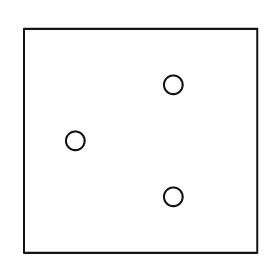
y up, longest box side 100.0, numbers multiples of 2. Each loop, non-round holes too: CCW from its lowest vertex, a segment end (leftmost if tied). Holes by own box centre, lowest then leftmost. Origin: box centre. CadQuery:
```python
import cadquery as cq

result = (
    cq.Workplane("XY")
    .moveTo(-50.0, -48.0)
    .lineTo(50.0, -48.0)
    .lineTo(50.0, 48.0)
    .lineTo(-50.0, 48.0)
    .close()
    .moveTo(14.0, -24.0)
    .circle(4.0)
    .moveTo(-28.0, 0.0)
    .circle(4.0)
    .moveTo(14.0, 24.0)
    .circle(4.0)
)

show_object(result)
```